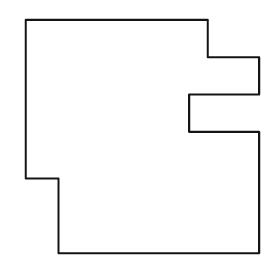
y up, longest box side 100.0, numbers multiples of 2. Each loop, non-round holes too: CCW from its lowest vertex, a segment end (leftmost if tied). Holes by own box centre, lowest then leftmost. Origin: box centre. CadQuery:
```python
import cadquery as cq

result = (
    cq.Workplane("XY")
    .moveTo(-36.0, -50.0)
    .lineTo(50.0, -50.0)
    .lineTo(50.0, 2.0)
    .lineTo(20.0, 2.0)
    .lineTo(20.0, 18.0)
    .lineTo(50.0, 18.0)
    .lineTo(50.0, 34.0)
    .lineTo(28.0, 34.0)
    .lineTo(28.0, 50.0)
    .lineTo(-50.0, 50.0)
    .lineTo(-50.0, -18.0)
    .lineTo(-36.0, -18.0)
    .close()
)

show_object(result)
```